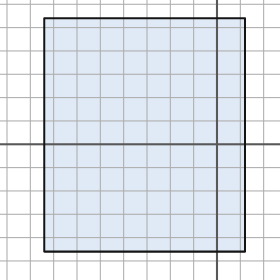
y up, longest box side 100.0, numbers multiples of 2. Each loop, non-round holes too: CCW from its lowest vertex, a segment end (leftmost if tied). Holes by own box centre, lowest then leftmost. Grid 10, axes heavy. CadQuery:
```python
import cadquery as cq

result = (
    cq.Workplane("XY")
    .moveTo(-74.0, -46.0)
    .lineTo(12.0, -46.0)
    .lineTo(12.0, 54.0)
    .lineTo(-74.0, 54.0)
    .close()
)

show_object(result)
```